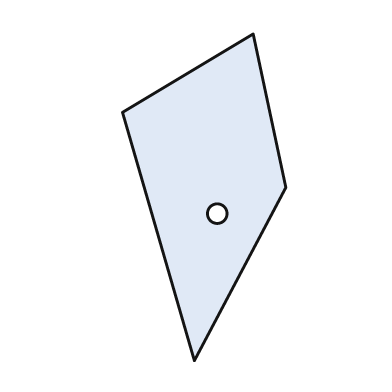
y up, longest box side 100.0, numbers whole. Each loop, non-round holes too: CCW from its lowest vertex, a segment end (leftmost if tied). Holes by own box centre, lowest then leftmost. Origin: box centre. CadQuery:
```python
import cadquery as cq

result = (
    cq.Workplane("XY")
    .moveTo(-3.0, -50.0)
    .lineTo(25.0, 3.0)
    .lineTo(15.0, 50.0)
    .lineTo(-25.0, 26.0)
    .close()
    .moveTo(4.0, -5.0)
    .circle(3.0)
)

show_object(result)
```